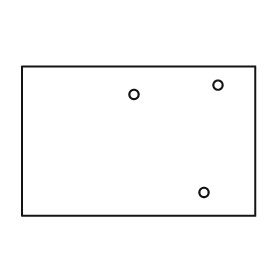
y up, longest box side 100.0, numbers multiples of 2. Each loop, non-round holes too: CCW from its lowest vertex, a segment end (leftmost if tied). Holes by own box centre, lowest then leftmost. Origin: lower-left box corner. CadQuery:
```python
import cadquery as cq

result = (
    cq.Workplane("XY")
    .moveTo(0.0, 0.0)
    .lineTo(100.0, 0.0)
    .lineTo(100.0, 64.0)
    .lineTo(0.0, 64.0)
    .close()
    .moveTo(78.0, 10.0)
    .circle(2.0)
    .moveTo(48.0, 52.0)
    .circle(2.0)
    .moveTo(84.0, 56.0)
    .circle(2.0)
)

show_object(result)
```